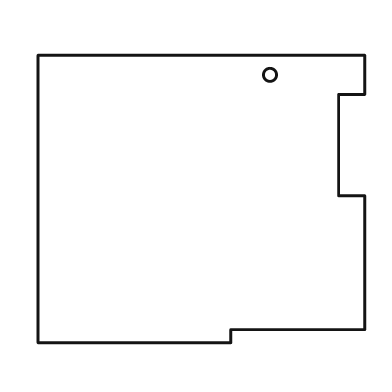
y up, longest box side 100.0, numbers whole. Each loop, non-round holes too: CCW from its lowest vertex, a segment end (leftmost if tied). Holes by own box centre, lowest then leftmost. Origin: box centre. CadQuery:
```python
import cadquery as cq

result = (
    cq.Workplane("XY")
    .moveTo(-50.0, -44.0)
    .lineTo(9.0, -44.0)
    .lineTo(9.0, -40.0)
    .lineTo(50.0, -40.0)
    .lineTo(50.0, 1.0)
    .lineTo(42.0, 1.0)
    .lineTo(42.0, 32.0)
    .lineTo(50.0, 32.0)
    .lineTo(50.0, 44.0)
    .lineTo(-50.0, 44.0)
    .close()
    .moveTo(21.0, 38.0)
    .circle(2.0)
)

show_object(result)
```